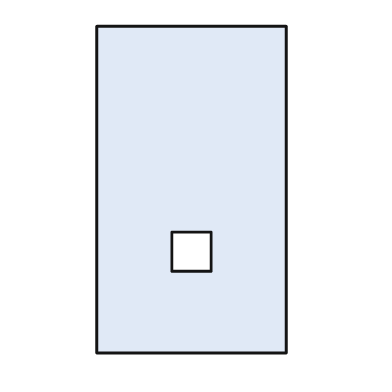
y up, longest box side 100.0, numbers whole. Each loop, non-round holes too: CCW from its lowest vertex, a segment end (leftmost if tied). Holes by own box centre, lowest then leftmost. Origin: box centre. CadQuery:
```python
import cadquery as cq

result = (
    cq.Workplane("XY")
    .moveTo(-29.0, -50.0)
    .lineTo(29.0, -50.0)
    .lineTo(29.0, 50.0)
    .lineTo(-29.0, 50.0)
    .close()
    .moveTo(-6.0, -25.0)
    .lineTo(6.0, -25.0)
    .lineTo(6.0, -13.0)
    .lineTo(-6.0, -13.0)
    .close()
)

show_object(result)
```